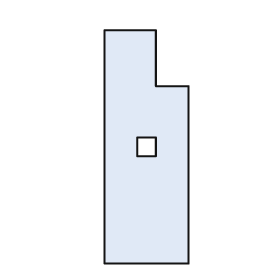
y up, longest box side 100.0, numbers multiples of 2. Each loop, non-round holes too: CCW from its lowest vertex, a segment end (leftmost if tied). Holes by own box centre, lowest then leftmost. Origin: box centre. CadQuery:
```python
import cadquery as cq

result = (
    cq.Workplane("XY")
    .moveTo(-18.0, -50.0)
    .lineTo(18.0, -50.0)
    .lineTo(18.0, 26.0)
    .lineTo(4.0, 26.0)
    .lineTo(4.0, 50.0)
    .lineTo(-18.0, 50.0)
    .close()
    .moveTo(-4.0, -4.0)
    .lineTo(4.0, -4.0)
    .lineTo(4.0, 4.0)
    .lineTo(-4.0, 4.0)
    .close()
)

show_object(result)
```